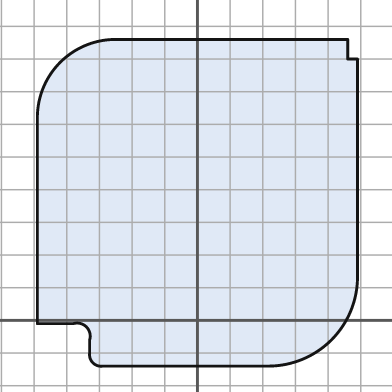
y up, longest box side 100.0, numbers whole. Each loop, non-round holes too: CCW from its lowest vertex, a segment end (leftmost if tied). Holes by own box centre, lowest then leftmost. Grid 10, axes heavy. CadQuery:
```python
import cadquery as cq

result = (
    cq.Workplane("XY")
    .moveTo(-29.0, -14.0)
    .lineTo(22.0, -14.0)
    .threePointArc((41.0, -6.0), (49.0, 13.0))
    .lineTo(49.0, 80.0)
    .lineTo(46.0, 80.0)
    .lineTo(46.0, 86.0)
    .lineTo(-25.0, 86.0)
    .threePointArc((-42.0, 79.0), (-49.0, 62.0))
    .lineTo(-49.0, -1.0)
    .lineTo(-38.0, -1.0)
    .threePointArc((-34.0, -2.0), (-33.0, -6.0))
    .lineTo(-33.0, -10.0)
    .threePointArc((-32.0, -13.0), (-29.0, -14.0))
    .close()
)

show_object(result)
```